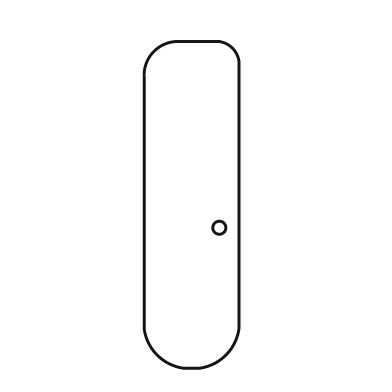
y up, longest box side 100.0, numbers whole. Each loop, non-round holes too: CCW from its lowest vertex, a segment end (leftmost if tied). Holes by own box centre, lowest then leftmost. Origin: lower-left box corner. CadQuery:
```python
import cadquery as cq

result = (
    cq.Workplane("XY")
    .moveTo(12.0, 0.0)
    .lineTo(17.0, 0.0)
    .threePointArc((25.0, 4.0), (29.0, 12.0))
    .lineTo(29.0, 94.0)
    .threePointArc((27.0, 98.0), (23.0, 100.0))
    .lineTo(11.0, 100.0)
    .threePointArc((3.0, 97.0), (0.0, 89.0))
    .lineTo(0.0, 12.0)
    .threePointArc((4.0, 4.0), (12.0, 0.0))
    .close()
    .moveTo(23.0, 43.0)
    .circle(2.0)
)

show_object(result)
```